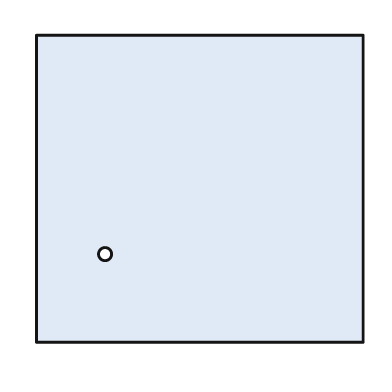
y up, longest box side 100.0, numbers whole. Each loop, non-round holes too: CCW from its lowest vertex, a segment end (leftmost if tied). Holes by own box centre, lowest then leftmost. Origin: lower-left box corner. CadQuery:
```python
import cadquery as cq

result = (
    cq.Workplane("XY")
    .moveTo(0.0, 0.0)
    .lineTo(100.0, 0.0)
    .lineTo(100.0, 94.0)
    .lineTo(0.0, 94.0)
    .close()
    .moveTo(21.0, 27.0)
    .circle(2.0)
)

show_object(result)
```